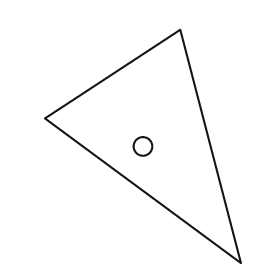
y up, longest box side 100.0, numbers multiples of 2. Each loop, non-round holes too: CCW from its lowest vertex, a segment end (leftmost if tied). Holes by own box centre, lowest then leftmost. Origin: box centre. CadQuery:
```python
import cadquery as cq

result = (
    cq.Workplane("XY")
    .moveTo(42.0, -50.0)
    .lineTo(16.0, 50.0)
    .lineTo(-42.0, 12.0)
    .close()
    .moveTo(0.0, 0.0)
    .circle(4.0)
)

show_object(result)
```